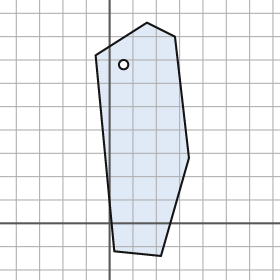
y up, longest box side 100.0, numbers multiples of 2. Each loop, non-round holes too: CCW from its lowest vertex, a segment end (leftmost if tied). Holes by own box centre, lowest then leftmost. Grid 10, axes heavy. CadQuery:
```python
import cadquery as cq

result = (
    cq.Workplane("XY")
    .moveTo(22.0, -14.0)
    .lineTo(34.0, 28.0)
    .lineTo(28.0, 80.0)
    .lineTo(16.0, 86.0)
    .lineTo(-6.0, 72.0)
    .lineTo(2.0, -12.0)
    .close()
    .moveTo(6.0, 68.0)
    .circle(2.0)
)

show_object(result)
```